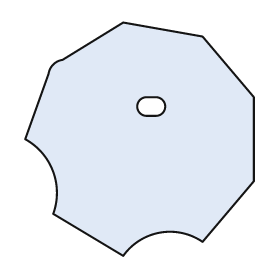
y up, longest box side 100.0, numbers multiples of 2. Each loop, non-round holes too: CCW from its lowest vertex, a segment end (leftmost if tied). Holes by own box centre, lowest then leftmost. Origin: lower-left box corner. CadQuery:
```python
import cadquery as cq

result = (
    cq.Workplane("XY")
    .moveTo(42.0, 0.0)
    .threePointArc((58.0, 10.0), (76.0, 6.0))
    .lineTo(98.0, 32.0)
    .lineTo(98.0, 68.0)
    .lineTo(76.0, 94.0)
    .lineTo(42.0, 100.0)
    .lineTo(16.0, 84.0)
    .threePointArc((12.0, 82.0), (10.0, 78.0))
    .lineTo(0.0, 50.0)
    .threePointArc((12.0, 36.0), (12.0, 18.0))
    .close()
    .moveTo(52.0, 60.0)
    .lineTo(56.0, 60.0)
    .threePointArc((60.0, 64.0), (56.0, 68.0))
    .lineTo(52.0, 68.0)
    .threePointArc((48.0, 64.0), (52.0, 60.0))
    .close()
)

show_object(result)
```